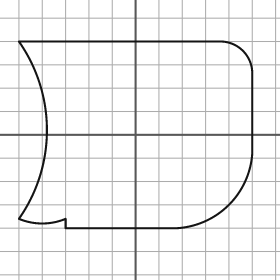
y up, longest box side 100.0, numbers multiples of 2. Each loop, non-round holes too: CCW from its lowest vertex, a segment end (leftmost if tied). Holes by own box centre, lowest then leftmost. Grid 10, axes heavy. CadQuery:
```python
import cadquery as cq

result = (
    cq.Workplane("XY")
    .moveTo(-30.0, -40.0)
    .lineTo(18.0, -40.0)
    .threePointArc((40.0, -30.0), (50.0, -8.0))
    .lineTo(50.0, 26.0)
    .threePointArc((46.0, 36.0), (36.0, 40.0))
    .lineTo(-50.0, 40.0)
    .threePointArc((-38.0, 2.0), (-50.0, -36.0))
    .threePointArc((-40.0, -38.0), (-30.0, -36.0))
    .close()
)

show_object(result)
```